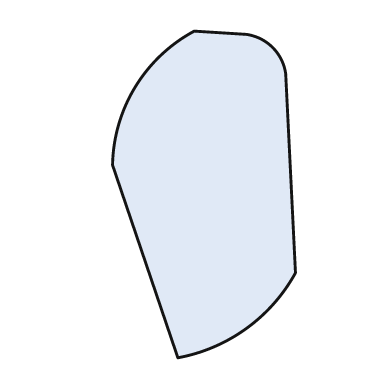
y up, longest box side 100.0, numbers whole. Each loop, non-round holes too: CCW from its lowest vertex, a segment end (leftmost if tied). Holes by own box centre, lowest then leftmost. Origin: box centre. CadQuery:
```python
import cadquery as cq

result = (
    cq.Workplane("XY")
    .moveTo(-8.0, -50.0)
    .threePointArc((13.0, -41.0), (28.0, -24.0))
    .lineTo(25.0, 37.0)
    .threePointArc((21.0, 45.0), (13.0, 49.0))
    .lineTo(-3.0, 50.0)
    .threePointArc((-21.0, 33.0), (-28.0, 9.0))
    .close()
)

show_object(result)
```